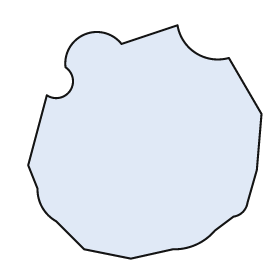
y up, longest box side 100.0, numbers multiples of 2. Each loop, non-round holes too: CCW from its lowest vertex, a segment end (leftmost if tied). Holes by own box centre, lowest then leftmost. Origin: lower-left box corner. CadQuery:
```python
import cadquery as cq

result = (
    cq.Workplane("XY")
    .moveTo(44.0, 0.0)
    .lineTo(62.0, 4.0)
    .threePointArc((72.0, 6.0), (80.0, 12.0))
    .lineTo(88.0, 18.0)
    .threePointArc((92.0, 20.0), (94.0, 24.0))
    .lineTo(98.0, 38.0)
    .lineTo(100.0, 62.0)
    .lineTo(86.0, 86.0)
    .threePointArc((72.0, 88.0), (64.0, 100.0))
    .lineTo(40.0, 92.0)
    .threePointArc((24.0, 96.0), (16.0, 82.0))
    .threePointArc((18.0, 72.0), (8.0, 70.0))
    .lineTo(0.0, 40.0)
    .lineTo(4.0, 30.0)
    .threePointArc((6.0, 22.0), (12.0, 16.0))
    .lineTo(24.0, 4.0)
    .close()
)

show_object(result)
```